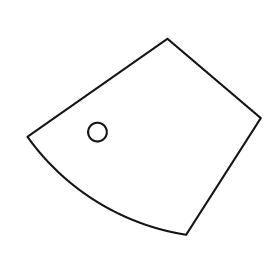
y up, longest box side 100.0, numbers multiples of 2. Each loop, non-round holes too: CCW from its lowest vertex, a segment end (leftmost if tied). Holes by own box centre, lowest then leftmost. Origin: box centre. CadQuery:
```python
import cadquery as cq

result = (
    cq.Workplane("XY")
    .moveTo(18.0, -42.0)
    .lineTo(50.0, 8.0)
    .lineTo(10.0, 42.0)
    .lineTo(-50.0, 0.0)
    .threePointArc((-20.0, -28.0), (18.0, -42.0))
    .close()
    .moveTo(-20.0, 2.0)
    .circle(4.0)
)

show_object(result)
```